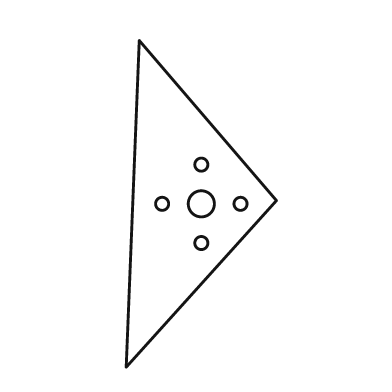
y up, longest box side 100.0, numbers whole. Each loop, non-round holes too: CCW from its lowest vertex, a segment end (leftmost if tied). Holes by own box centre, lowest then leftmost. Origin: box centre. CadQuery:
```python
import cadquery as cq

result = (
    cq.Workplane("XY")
    .moveTo(-23.0, -50.0)
    .lineTo(23.0, 1.0)
    .lineTo(-19.0, 50.0)
    .close()
    .moveTo(0.0, -12.0)
    .circle(2.0)
    .moveTo(-12.0, 0.0)
    .circle(2.0)
    .moveTo(0.0, 0.0)
    .circle(4.0)
    .moveTo(12.0, 0.0)
    .circle(2.0)
    .moveTo(0.0, 12.0)
    .circle(2.0)
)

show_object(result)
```